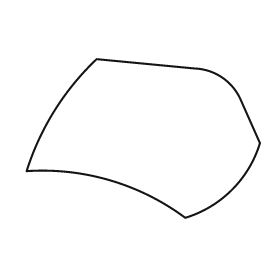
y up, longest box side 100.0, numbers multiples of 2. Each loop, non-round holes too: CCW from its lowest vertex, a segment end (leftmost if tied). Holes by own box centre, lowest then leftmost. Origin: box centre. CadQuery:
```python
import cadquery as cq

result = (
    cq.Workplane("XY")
    .moveTo(18.0, -34.0)
    .threePointArc((38.0, -22.0), (50.0, -2.0))
    .lineTo(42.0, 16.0)
    .threePointArc((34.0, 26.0), (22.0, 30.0))
    .lineTo(-20.0, 34.0)
    .threePointArc((-38.0, 12.0), (-50.0, -14.0))
    .threePointArc((-14.0, -18.0), (18.0, -34.0))
    .close()
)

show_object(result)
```